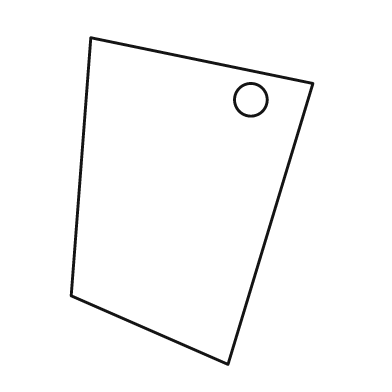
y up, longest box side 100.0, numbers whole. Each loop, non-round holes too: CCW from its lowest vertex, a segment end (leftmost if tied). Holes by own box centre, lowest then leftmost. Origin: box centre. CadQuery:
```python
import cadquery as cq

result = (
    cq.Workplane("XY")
    .moveTo(11.0, -50.0)
    .lineTo(37.0, 36.0)
    .lineTo(-31.0, 50.0)
    .lineTo(-37.0, -29.0)
    .close()
    .moveTo(18.0, 31.0)
    .circle(5.0)
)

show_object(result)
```